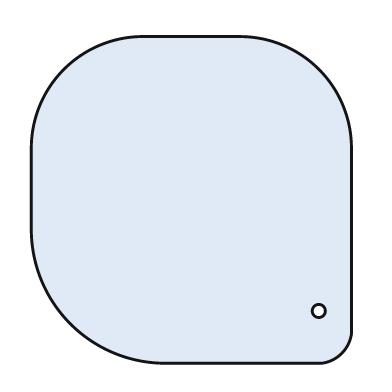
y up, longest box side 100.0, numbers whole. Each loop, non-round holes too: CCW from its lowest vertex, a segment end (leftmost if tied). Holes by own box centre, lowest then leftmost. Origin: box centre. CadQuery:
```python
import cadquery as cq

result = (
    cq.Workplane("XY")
    .moveTo(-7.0, -50.0)
    .lineTo(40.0, -50.0)
    .threePointArc((46.0, -47.0), (49.0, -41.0))
    .lineTo(49.0, 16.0)
    .threePointArc((39.0, 40.0), (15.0, 50.0))
    .lineTo(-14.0, 50.0)
    .threePointArc((-39.0, 40.0), (-49.0, 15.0))
    .lineTo(-49.0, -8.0)
    .threePointArc((-37.0, -38.0), (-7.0, -50.0))
    .close()
    .moveTo(39.0, -34.0)
    .circle(2.0)
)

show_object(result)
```